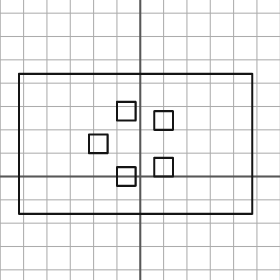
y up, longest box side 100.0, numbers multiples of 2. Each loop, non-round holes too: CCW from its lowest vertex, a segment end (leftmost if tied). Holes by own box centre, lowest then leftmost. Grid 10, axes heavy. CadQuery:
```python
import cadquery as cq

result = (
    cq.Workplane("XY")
    .moveTo(-52.0, -16.0)
    .lineTo(48.0, -16.0)
    .lineTo(48.0, 44.0)
    .lineTo(-52.0, 44.0)
    .close()
    .moveTo(-10.0, -4.0)
    .lineTo(-2.0, -4.0)
    .lineTo(-2.0, 4.0)
    .lineTo(-10.0, 4.0)
    .close()
    .moveTo(6.0, 0.0)
    .lineTo(14.0, 0.0)
    .lineTo(14.0, 8.0)
    .lineTo(6.0, 8.0)
    .close()
    .moveTo(-22.0, 10.0)
    .lineTo(-14.0, 10.0)
    .lineTo(-14.0, 18.0)
    .lineTo(-22.0, 18.0)
    .close()
    .moveTo(6.0, 20.0)
    .lineTo(14.0, 20.0)
    .lineTo(14.0, 28.0)
    .lineTo(6.0, 28.0)
    .close()
    .moveTo(-10.0, 24.0)
    .lineTo(-2.0, 24.0)
    .lineTo(-2.0, 32.0)
    .lineTo(-10.0, 32.0)
    .close()
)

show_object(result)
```